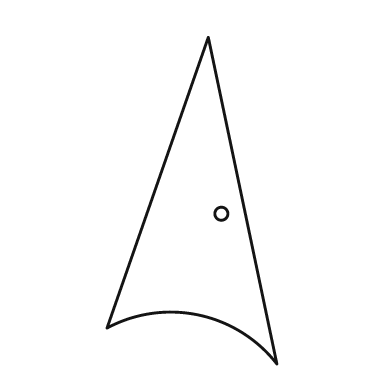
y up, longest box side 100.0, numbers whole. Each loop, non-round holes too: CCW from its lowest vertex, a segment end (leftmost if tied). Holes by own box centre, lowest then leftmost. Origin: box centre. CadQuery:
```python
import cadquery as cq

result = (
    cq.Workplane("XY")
    .moveTo(26.0, -50.0)
    .lineTo(5.0, 50.0)
    .lineTo(-26.0, -39.0)
    .threePointArc((2.0, -35.0), (26.0, -50.0))
    .close()
    .moveTo(9.0, -4.0)
    .circle(2.0)
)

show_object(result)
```